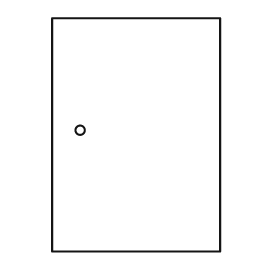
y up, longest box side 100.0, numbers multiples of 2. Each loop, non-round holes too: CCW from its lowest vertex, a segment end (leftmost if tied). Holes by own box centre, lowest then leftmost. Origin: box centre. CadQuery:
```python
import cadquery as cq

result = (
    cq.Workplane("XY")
    .moveTo(-36.0, -50.0)
    .lineTo(36.0, -50.0)
    .lineTo(36.0, 50.0)
    .lineTo(-36.0, 50.0)
    .close()
    .moveTo(-24.0, 2.0)
    .circle(2.0)
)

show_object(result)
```